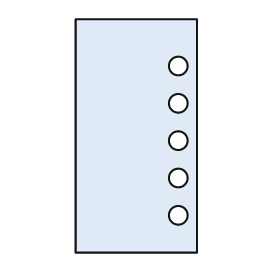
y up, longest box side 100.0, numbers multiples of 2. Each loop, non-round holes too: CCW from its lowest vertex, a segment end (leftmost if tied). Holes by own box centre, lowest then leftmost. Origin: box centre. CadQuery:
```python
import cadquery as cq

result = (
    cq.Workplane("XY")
    .moveTo(-26.0, -50.0)
    .lineTo(26.0, -50.0)
    .lineTo(26.0, 50.0)
    .lineTo(-26.0, 50.0)
    .close()
    .moveTo(18.0, -34.0)
    .circle(4.0)
    .moveTo(18.0, -18.0)
    .circle(4.0)
    .moveTo(18.0, -2.0)
    .circle(4.0)
    .moveTo(18.0, 14.0)
    .circle(4.0)
    .moveTo(18.0, 30.0)
    .circle(4.0)
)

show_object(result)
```